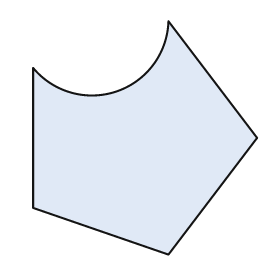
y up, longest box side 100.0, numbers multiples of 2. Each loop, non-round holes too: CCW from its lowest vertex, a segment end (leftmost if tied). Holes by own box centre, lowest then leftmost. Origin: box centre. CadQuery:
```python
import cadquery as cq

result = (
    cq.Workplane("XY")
    .moveTo(10.0, -50.0)
    .lineTo(48.0, 0.0)
    .lineTo(10.0, 50.0)
    .threePointArc((-12.0, 20.0), (-48.0, 30.0))
    .lineTo(-48.0, -30.0)
    .close()
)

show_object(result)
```